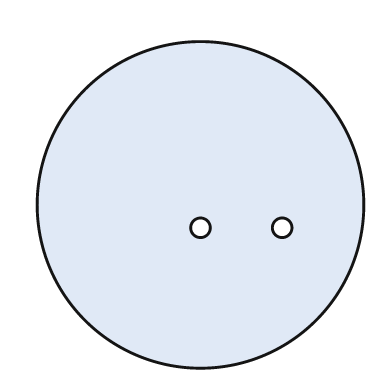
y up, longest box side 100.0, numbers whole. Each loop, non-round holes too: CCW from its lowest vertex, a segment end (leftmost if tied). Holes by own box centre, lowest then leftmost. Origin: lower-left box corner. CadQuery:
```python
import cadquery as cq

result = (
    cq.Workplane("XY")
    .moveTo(50.0, 50.0)
    .circle(50.0)
    .moveTo(50.0, 43.0)
    .circle(3.0)
    .moveTo(75.0, 43.0)
    .circle(3.0)
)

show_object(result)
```